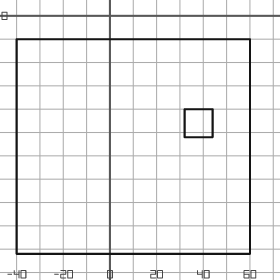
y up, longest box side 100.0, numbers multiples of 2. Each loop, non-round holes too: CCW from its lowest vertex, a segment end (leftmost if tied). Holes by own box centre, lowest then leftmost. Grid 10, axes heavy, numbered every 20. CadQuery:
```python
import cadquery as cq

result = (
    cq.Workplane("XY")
    .moveTo(-40.0, -102.0)
    .lineTo(60.0, -102.0)
    .lineTo(60.0, -10.0)
    .lineTo(-40.0, -10.0)
    .close()
    .moveTo(32.0, -52.0)
    .lineTo(44.0, -52.0)
    .lineTo(44.0, -40.0)
    .lineTo(32.0, -40.0)
    .close()
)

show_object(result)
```